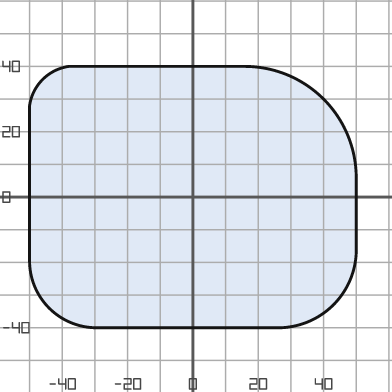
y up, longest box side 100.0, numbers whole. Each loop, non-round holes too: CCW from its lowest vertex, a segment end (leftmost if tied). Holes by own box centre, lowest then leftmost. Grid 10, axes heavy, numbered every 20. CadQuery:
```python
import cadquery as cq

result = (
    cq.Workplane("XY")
    .moveTo(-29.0, -40.0)
    .lineTo(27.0, -40.0)
    .threePointArc((43.0, -33.0), (50.0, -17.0))
    .lineTo(50.0, 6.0)
    .threePointArc((40.0, 30.0), (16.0, 40.0))
    .lineTo(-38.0, 40.0)
    .threePointArc((-46.0, 36.0), (-50.0, 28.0))
    .lineTo(-50.0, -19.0)
    .threePointArc((-44.0, -34.0), (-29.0, -40.0))
    .close()
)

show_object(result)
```